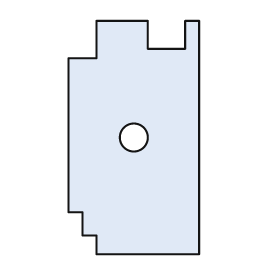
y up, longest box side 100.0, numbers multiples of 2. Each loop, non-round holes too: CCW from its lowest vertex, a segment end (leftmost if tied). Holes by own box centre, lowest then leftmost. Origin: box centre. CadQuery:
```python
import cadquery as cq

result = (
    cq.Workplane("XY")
    .moveTo(-16.0, -50.0)
    .lineTo(28.0, -50.0)
    .lineTo(28.0, 50.0)
    .lineTo(22.0, 50.0)
    .lineTo(22.0, 38.0)
    .lineTo(6.0, 38.0)
    .lineTo(6.0, 50.0)
    .lineTo(-16.0, 50.0)
    .lineTo(-16.0, 34.0)
    .lineTo(-28.0, 34.0)
    .lineTo(-28.0, -32.0)
    .lineTo(-22.0, -32.0)
    .lineTo(-22.0, -42.0)
    .lineTo(-16.0, -42.0)
    .close()
    .moveTo(0.0, 0.0)
    .circle(6.0)
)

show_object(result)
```